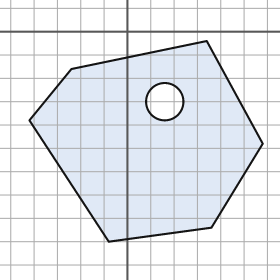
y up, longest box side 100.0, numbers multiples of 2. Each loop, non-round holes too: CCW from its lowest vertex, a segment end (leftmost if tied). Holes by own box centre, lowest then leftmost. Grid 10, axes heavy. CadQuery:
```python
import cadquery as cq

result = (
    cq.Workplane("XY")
    .moveTo(-8.0, -90.0)
    .lineTo(36.0, -84.0)
    .lineTo(58.0, -48.0)
    .lineTo(34.0, -4.0)
    .lineTo(-24.0, -16.0)
    .lineTo(-42.0, -38.0)
    .close()
    .moveTo(16.0, -30.0)
    .circle(8.0)
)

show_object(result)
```